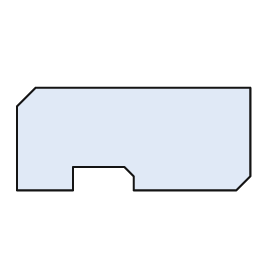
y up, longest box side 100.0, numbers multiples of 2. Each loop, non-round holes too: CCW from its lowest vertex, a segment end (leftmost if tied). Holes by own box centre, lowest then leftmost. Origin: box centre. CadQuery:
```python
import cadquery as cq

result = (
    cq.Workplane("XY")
    .moveTo(-50.0, -22.0)
    .lineTo(-26.0, -22.0)
    .lineTo(-26.0, -12.0)
    .lineTo(-4.0, -12.0)
    .lineTo(0.0, -16.0)
    .lineTo(0.0, -22.0)
    .lineTo(44.0, -22.0)
    .lineTo(50.0, -16.0)
    .lineTo(50.0, 22.0)
    .lineTo(-42.0, 22.0)
    .lineTo(-50.0, 14.0)
    .close()
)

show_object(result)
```